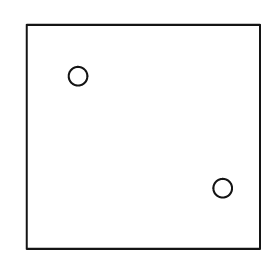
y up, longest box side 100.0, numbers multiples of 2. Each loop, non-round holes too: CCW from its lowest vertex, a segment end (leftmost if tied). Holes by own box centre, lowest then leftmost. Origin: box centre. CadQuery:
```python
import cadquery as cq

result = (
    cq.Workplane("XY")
    .moveTo(-50.0, -48.0)
    .lineTo(50.0, -48.0)
    .lineTo(50.0, 48.0)
    .lineTo(-50.0, 48.0)
    .close()
    .moveTo(34.0, -22.0)
    .circle(4.0)
    .moveTo(-28.0, 26.0)
    .circle(4.0)
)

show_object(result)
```